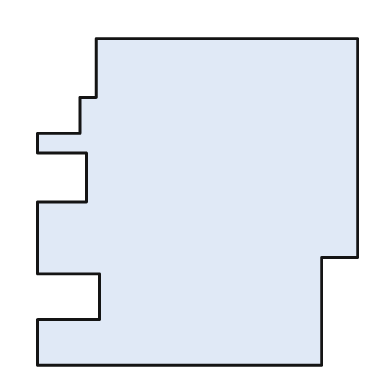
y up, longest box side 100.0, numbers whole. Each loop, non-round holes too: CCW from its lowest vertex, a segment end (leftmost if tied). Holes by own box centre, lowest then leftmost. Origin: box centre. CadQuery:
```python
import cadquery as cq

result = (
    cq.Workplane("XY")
    .moveTo(-49.0, -50.0)
    .lineTo(38.0, -50.0)
    .lineTo(38.0, -17.0)
    .lineTo(49.0, -17.0)
    .lineTo(49.0, 50.0)
    .lineTo(-31.0, 50.0)
    .lineTo(-31.0, 32.0)
    .lineTo(-36.0, 32.0)
    .lineTo(-36.0, 21.0)
    .lineTo(-49.0, 21.0)
    .lineTo(-49.0, 15.0)
    .lineTo(-34.0, 15.0)
    .lineTo(-34.0, 0.0)
    .lineTo(-49.0, 0.0)
    .lineTo(-49.0, -22.0)
    .lineTo(-30.0, -22.0)
    .lineTo(-30.0, -36.0)
    .lineTo(-49.0, -36.0)
    .close()
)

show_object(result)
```